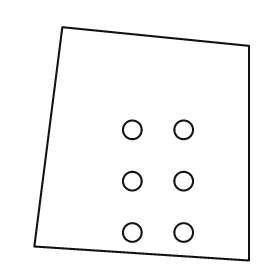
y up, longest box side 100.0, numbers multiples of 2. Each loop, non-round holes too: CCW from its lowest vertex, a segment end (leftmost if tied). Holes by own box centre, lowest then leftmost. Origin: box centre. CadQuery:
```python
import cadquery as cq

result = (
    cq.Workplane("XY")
    .moveTo(46.0, -50.0)
    .lineTo(46.0, 42.0)
    .lineTo(-34.0, 50.0)
    .lineTo(-46.0, -44.0)
    .close()
    .moveTo(-4.0, -38.0)
    .circle(4.0)
    .moveTo(18.0, -38.0)
    .circle(4.0)
    .moveTo(-4.0, -16.0)
    .circle(4.0)
    .moveTo(18.0, -16.0)
    .circle(4.0)
    .moveTo(-4.0, 6.0)
    .circle(4.0)
    .moveTo(18.0, 6.0)
    .circle(4.0)
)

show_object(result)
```